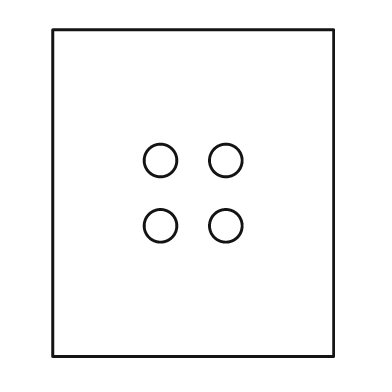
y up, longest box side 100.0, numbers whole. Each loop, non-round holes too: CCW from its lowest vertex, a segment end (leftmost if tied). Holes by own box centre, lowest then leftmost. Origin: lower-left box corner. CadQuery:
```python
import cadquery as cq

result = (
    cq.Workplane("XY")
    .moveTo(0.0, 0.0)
    .lineTo(86.0, 0.0)
    .lineTo(86.0, 100.0)
    .lineTo(0.0, 100.0)
    .close()
    .moveTo(33.0, 40.0)
    .circle(5.0)
    .moveTo(53.0, 40.0)
    .circle(5.0)
    .moveTo(33.0, 60.0)
    .circle(5.0)
    .moveTo(53.0, 60.0)
    .circle(5.0)
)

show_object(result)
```